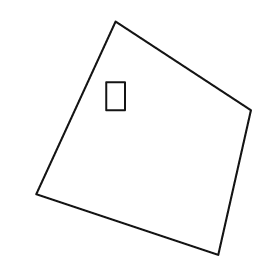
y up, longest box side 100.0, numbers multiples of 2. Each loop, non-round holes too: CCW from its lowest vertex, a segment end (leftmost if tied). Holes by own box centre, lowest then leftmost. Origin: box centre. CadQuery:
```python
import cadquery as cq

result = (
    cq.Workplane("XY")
    .moveTo(32.0, -50.0)
    .lineTo(46.0, 12.0)
    .lineTo(-12.0, 50.0)
    .lineTo(-46.0, -24.0)
    .close()
    .moveTo(-16.0, 12.0)
    .lineTo(-8.0, 12.0)
    .lineTo(-8.0, 24.0)
    .lineTo(-16.0, 24.0)
    .close()
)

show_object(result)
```